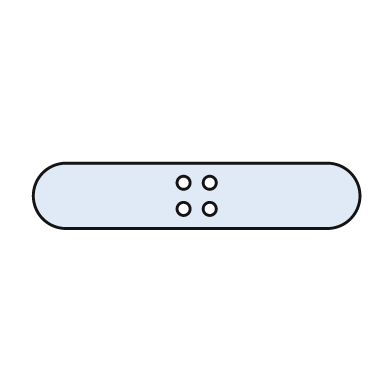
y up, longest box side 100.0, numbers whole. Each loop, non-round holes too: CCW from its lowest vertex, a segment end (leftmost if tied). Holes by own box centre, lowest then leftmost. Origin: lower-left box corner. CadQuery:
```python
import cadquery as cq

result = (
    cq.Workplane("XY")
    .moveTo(10.0, 0.0)
    .lineTo(90.0, 0.0)
    .threePointArc((100.0, 10.0), (90.0, 20.0))
    .lineTo(10.0, 20.0)
    .threePointArc((0.0, 10.0), (10.0, 0.0))
    .close()
    .moveTo(46.0, 6.0)
    .circle(2.0)
    .moveTo(54.0, 6.0)
    .circle(2.0)
    .moveTo(46.0, 14.0)
    .circle(2.0)
    .moveTo(54.0, 14.0)
    .circle(2.0)
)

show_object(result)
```